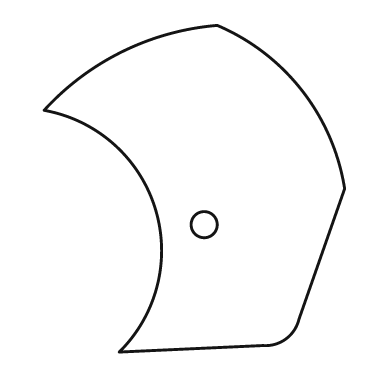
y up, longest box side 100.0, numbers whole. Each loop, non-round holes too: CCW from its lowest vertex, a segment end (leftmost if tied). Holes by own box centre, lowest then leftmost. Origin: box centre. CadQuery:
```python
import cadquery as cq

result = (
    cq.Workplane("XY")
    .moveTo(-23.0, -50.0)
    .lineTo(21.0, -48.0)
    .threePointArc((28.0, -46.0), (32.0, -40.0))
    .lineTo(46.0, 0.0)
    .threePointArc((33.0, 30.0), (7.0, 50.0))
    .threePointArc((-22.0, 42.0), (-46.0, 24.0))
    .threePointArc((-12.0, -6.0), (-23.0, -50.0))
    .close()
    .moveTo(3.0, -11.0)
    .circle(4.0)
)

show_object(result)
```